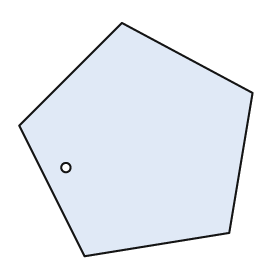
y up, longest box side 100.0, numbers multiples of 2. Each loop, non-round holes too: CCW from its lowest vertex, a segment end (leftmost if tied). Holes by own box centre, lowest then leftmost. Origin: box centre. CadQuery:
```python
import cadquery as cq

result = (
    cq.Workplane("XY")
    .moveTo(-22.0, -50.0)
    .lineTo(40.0, -40.0)
    .lineTo(50.0, 20.0)
    .lineTo(-6.0, 50.0)
    .lineTo(-50.0, 6.0)
    .close()
    .moveTo(-30.0, -12.0)
    .circle(2.0)
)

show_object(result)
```